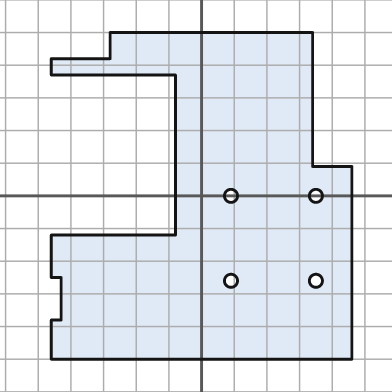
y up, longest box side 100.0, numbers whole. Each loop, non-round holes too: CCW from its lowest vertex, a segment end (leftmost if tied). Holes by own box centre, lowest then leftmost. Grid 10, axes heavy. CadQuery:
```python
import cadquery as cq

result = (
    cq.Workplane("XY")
    .moveTo(-46.0, -50.0)
    .lineTo(46.0, -50.0)
    .lineTo(46.0, 9.0)
    .lineTo(34.0, 9.0)
    .lineTo(34.0, 50.0)
    .lineTo(-28.0, 50.0)
    .lineTo(-28.0, 42.0)
    .lineTo(-46.0, 42.0)
    .lineTo(-46.0, 37.0)
    .lineTo(-8.0, 37.0)
    .lineTo(-8.0, -12.0)
    .lineTo(-46.0, -12.0)
    .lineTo(-46.0, -25.0)
    .lineTo(-43.0, -25.0)
    .lineTo(-43.0, -38.0)
    .lineTo(-46.0, -38.0)
    .close()
    .moveTo(9.0, -26.0)
    .circle(2.0)
    .moveTo(35.0, -26.0)
    .circle(2.0)
    .moveTo(9.0, 0.0)
    .circle(2.0)
    .moveTo(35.0, 0.0)
    .circle(2.0)
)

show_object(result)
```